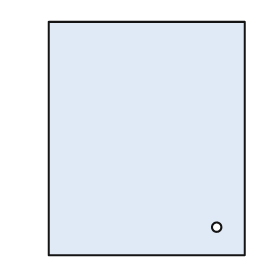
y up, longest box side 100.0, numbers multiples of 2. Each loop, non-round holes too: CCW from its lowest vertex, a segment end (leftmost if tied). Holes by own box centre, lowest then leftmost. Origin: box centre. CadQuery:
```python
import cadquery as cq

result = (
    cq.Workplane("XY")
    .moveTo(-42.0, -50.0)
    .lineTo(42.0, -50.0)
    .lineTo(42.0, 50.0)
    .lineTo(-42.0, 50.0)
    .close()
    .moveTo(30.0, -38.0)
    .circle(2.0)
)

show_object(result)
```